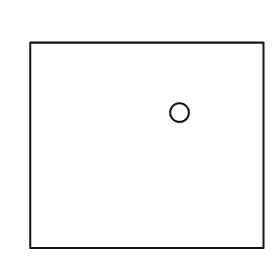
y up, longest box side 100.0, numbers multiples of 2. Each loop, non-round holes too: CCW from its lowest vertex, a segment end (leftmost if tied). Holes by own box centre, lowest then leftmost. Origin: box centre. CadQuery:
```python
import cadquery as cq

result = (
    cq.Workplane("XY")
    .moveTo(-50.0, -44.0)
    .lineTo(50.0, -44.0)
    .lineTo(50.0, 44.0)
    .lineTo(-50.0, 44.0)
    .close()
    .moveTo(14.0, 14.0)
    .circle(4.0)
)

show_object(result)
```